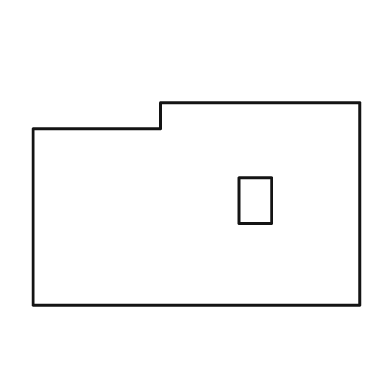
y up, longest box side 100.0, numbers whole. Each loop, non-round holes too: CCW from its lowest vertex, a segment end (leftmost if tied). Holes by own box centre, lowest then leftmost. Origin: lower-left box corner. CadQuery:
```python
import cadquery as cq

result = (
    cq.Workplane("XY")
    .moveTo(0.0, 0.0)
    .lineTo(100.0, 0.0)
    .lineTo(100.0, 62.0)
    .lineTo(39.0, 62.0)
    .lineTo(39.0, 54.0)
    .lineTo(0.0, 54.0)
    .close()
    .moveTo(63.0, 25.0)
    .lineTo(73.0, 25.0)
    .lineTo(73.0, 39.0)
    .lineTo(63.0, 39.0)
    .close()
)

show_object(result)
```